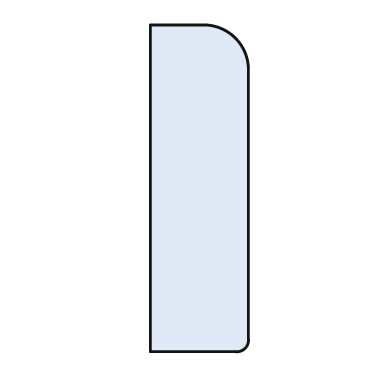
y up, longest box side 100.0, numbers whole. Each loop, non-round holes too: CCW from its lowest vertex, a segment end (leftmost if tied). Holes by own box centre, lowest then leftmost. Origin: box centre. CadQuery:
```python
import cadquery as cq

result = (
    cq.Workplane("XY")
    .moveTo(-15.0, -50.0)
    .lineTo(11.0, -50.0)
    .threePointArc((14.0, -49.0), (15.0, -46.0))
    .lineTo(15.0, 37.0)
    .threePointArc((11.0, 46.0), (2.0, 50.0))
    .lineTo(-15.0, 50.0)
    .close()
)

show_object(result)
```